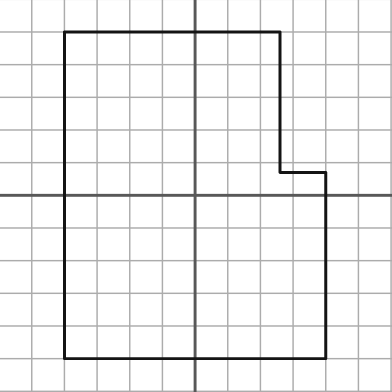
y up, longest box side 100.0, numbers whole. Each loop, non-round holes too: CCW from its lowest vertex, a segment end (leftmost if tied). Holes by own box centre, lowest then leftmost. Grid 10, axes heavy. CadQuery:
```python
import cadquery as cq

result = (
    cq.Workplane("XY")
    .moveTo(-40.0, -50.0)
    .lineTo(40.0, -50.0)
    .lineTo(40.0, 7.0)
    .lineTo(26.0, 7.0)
    .lineTo(26.0, 50.0)
    .lineTo(-40.0, 50.0)
    .close()
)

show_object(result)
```